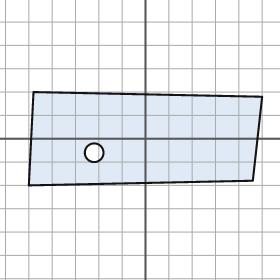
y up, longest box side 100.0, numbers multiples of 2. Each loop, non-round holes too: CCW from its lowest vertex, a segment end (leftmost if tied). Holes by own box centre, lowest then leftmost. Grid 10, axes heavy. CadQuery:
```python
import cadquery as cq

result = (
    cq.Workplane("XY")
    .moveTo(-50.0, -20.0)
    .lineTo(46.0, -18.0)
    .lineTo(50.0, 18.0)
    .lineTo(-48.0, 20.0)
    .close()
    .moveTo(-22.0, -6.0)
    .circle(4.0)
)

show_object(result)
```